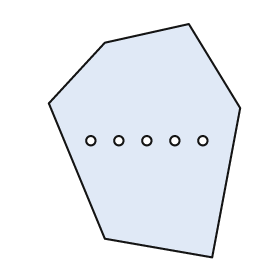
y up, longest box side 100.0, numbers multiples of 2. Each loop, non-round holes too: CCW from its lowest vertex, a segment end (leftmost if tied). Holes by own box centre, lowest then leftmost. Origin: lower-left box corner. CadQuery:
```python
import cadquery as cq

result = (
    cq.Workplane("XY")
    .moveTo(70.0, 0.0)
    .lineTo(82.0, 64.0)
    .lineTo(60.0, 100.0)
    .lineTo(24.0, 92.0)
    .lineTo(0.0, 66.0)
    .lineTo(24.0, 8.0)
    .close()
    .moveTo(18.0, 50.0)
    .circle(2.0)
    .moveTo(30.0, 50.0)
    .circle(2.0)
    .moveTo(42.0, 50.0)
    .circle(2.0)
    .moveTo(54.0, 50.0)
    .circle(2.0)
    .moveTo(66.0, 50.0)
    .circle(2.0)
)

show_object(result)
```